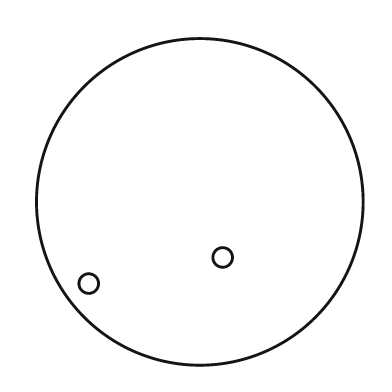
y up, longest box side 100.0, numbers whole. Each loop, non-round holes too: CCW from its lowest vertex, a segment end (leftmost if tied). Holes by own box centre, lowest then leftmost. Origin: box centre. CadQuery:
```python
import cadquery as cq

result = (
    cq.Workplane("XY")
    .moveTo(0.0, 0.0)
    .circle(50.0)
    .moveTo(-34.0, -25.0)
    .circle(3.0)
    .moveTo(7.0, -17.0)
    .circle(3.0)
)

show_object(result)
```